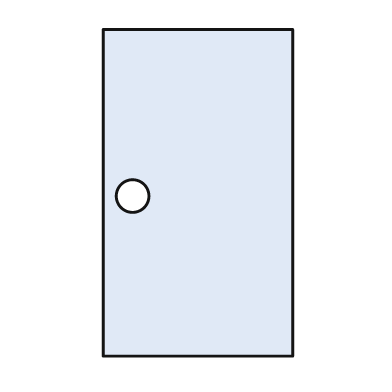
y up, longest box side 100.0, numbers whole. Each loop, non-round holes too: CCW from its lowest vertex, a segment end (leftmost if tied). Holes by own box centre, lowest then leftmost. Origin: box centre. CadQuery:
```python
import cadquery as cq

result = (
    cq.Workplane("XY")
    .moveTo(-29.0, -50.0)
    .lineTo(29.0, -50.0)
    .lineTo(29.0, 50.0)
    .lineTo(-29.0, 50.0)
    .close()
    .moveTo(-20.0, -1.0)
    .circle(5.0)
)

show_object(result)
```